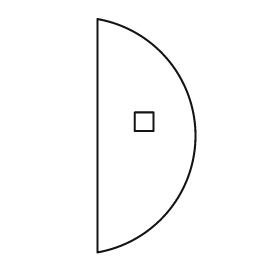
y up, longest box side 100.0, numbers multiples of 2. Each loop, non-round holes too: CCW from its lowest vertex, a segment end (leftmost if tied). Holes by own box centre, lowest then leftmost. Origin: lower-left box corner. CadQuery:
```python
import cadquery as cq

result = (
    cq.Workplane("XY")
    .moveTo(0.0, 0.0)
    .threePointArc((42.0, 50.0), (0.0, 100.0))
    .close()
    .moveTo(16.0, 52.0)
    .lineTo(24.0, 52.0)
    .lineTo(24.0, 60.0)
    .lineTo(16.0, 60.0)
    .close()
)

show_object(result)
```